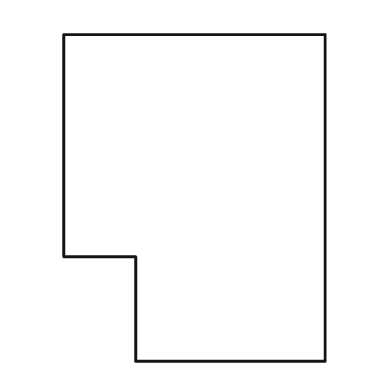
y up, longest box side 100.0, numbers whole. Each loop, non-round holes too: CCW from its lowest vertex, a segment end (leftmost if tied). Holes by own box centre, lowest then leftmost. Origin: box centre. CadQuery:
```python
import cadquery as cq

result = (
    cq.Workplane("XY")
    .moveTo(-18.0, -50.0)
    .lineTo(40.0, -50.0)
    .lineTo(40.0, 50.0)
    .lineTo(-40.0, 50.0)
    .lineTo(-40.0, -18.0)
    .lineTo(-18.0, -18.0)
    .close()
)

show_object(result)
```